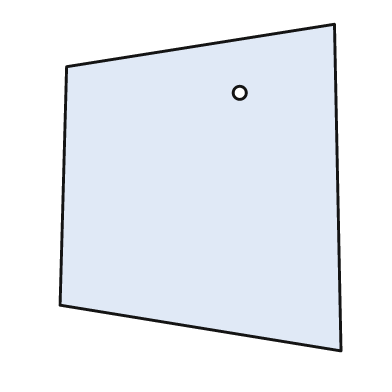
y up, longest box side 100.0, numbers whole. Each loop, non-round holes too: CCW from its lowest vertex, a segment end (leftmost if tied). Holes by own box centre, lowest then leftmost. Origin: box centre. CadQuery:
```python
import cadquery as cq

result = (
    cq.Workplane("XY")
    .moveTo(43.0, -50.0)
    .lineTo(41.0, 50.0)
    .lineTo(-41.0, 37.0)
    .lineTo(-43.0, -36.0)
    .close()
    .moveTo(12.0, 29.0)
    .circle(2.0)
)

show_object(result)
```